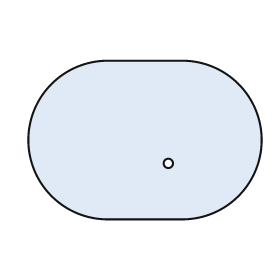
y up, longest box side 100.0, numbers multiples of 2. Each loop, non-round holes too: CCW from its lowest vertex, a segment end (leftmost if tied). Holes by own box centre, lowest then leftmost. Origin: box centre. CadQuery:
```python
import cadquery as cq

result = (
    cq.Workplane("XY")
    .moveTo(-16.0, -34.0)
    .lineTo(16.0, -34.0)
    .threePointArc((50.0, 0.0), (16.0, 34.0))
    .lineTo(-16.0, 34.0)
    .threePointArc((-50.0, 0.0), (-16.0, -34.0))
    .close()
    .moveTo(10.0, -10.0)
    .circle(2.0)
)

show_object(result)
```